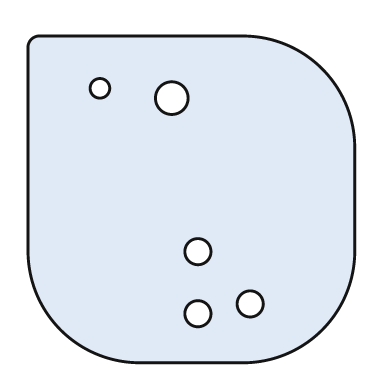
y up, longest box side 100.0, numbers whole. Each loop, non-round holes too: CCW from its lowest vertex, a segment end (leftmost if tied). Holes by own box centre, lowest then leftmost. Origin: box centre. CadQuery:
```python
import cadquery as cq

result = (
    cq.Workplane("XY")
    .moveTo(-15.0, -50.0)
    .lineTo(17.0, -50.0)
    .threePointArc((40.0, -40.0), (50.0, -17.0))
    .lineTo(50.0, 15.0)
    .threePointArc((40.0, 40.0), (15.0, 50.0))
    .lineTo(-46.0, 50.0)
    .threePointArc((-49.0, 49.0), (-50.0, 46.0))
    .lineTo(-50.0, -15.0)
    .threePointArc((-40.0, -40.0), (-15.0, -50.0))
    .close()
    .moveTo(2.0, -35.0)
    .circle(4.0)
    .moveTo(18.0, -32.0)
    .circle(4.0)
    .moveTo(2.0, -16.0)
    .circle(4.0)
    .moveTo(-6.0, 31.0)
    .circle(5.0)
    .moveTo(-28.0, 34.0)
    .circle(3.0)
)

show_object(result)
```